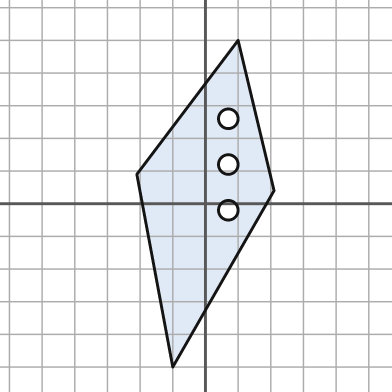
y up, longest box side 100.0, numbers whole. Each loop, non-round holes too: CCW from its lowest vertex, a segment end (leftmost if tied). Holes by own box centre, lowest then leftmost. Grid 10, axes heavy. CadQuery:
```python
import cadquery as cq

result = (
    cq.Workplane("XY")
    .moveTo(-10.0, -50.0)
    .lineTo(21.0, 4.0)
    .lineTo(10.0, 50.0)
    .lineTo(-21.0, 9.0)
    .close()
    .moveTo(7.0, -2.0)
    .circle(3.0)
    .moveTo(7.0, 12.0)
    .circle(3.0)
    .moveTo(7.0, 26.0)
    .circle(3.0)
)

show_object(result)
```